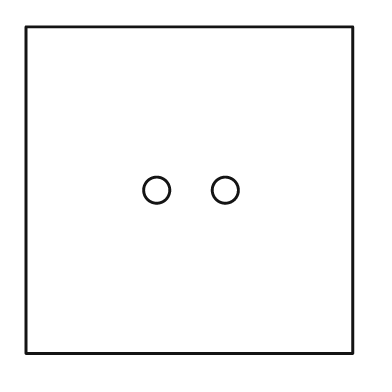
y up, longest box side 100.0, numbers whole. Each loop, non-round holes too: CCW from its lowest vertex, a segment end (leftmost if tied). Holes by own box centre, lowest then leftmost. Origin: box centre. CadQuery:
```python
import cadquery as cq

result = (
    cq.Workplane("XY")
    .moveTo(-50.0, -50.0)
    .lineTo(50.0, -50.0)
    .lineTo(50.0, 50.0)
    .lineTo(-50.0, 50.0)
    .close()
    .moveTo(-10.0, 0.0)
    .circle(4.0)
    .moveTo(11.0, 0.0)
    .circle(4.0)
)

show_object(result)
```